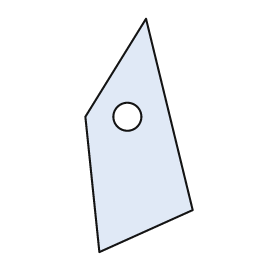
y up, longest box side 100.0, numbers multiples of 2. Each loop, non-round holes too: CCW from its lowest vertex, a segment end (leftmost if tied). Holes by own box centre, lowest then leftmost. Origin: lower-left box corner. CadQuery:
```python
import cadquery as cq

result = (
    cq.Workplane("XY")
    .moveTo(6.0, 0.0)
    .lineTo(46.0, 18.0)
    .lineTo(26.0, 100.0)
    .lineTo(0.0, 58.0)
    .close()
    .moveTo(18.0, 58.0)
    .circle(6.0)
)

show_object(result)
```